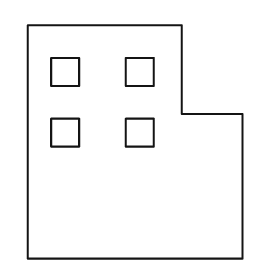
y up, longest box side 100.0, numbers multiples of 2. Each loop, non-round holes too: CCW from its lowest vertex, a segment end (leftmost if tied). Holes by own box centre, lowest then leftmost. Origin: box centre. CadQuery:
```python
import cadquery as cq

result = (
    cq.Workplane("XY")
    .moveTo(-46.0, -50.0)
    .lineTo(46.0, -50.0)
    .lineTo(46.0, 12.0)
    .lineTo(20.0, 12.0)
    .lineTo(20.0, 50.0)
    .lineTo(-46.0, 50.0)
    .close()
    .moveTo(-36.0, -2.0)
    .lineTo(-24.0, -2.0)
    .lineTo(-24.0, 10.0)
    .lineTo(-36.0, 10.0)
    .close()
    .moveTo(-4.0, -2.0)
    .lineTo(8.0, -2.0)
    .lineTo(8.0, 10.0)
    .lineTo(-4.0, 10.0)
    .close()
    .moveTo(-36.0, 24.0)
    .lineTo(-24.0, 24.0)
    .lineTo(-24.0, 36.0)
    .lineTo(-36.0, 36.0)
    .close()
    .moveTo(-4.0, 24.0)
    .lineTo(8.0, 24.0)
    .lineTo(8.0, 36.0)
    .lineTo(-4.0, 36.0)
    .close()
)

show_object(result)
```